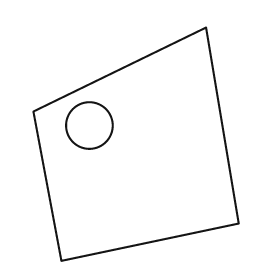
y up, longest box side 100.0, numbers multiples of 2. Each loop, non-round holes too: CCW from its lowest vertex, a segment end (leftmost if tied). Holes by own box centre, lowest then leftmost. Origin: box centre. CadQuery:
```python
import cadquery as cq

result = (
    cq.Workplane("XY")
    .moveTo(-32.0, -50.0)
    .lineTo(44.0, -34.0)
    .lineTo(30.0, 50.0)
    .lineTo(-44.0, 14.0)
    .close()
    .moveTo(-20.0, 8.0)
    .circle(10.0)
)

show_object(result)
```